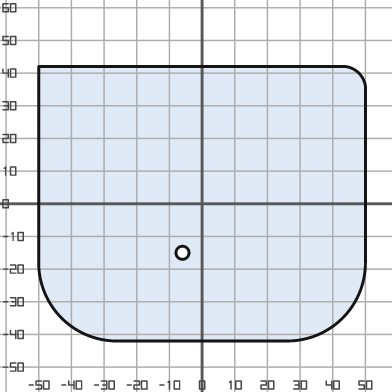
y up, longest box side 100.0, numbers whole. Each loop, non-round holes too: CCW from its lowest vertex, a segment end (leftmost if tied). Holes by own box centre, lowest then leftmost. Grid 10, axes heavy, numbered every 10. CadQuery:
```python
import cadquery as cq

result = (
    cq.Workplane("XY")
    .moveTo(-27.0, -42.0)
    .lineTo(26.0, -42.0)
    .threePointArc((43.0, -35.0), (50.0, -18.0))
    .lineTo(50.0, 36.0)
    .threePointArc((48.0, 40.0), (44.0, 42.0))
    .lineTo(-50.0, 42.0)
    .lineTo(-50.0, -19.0)
    .threePointArc((-43.0, -35.0), (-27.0, -42.0))
    .close()
    .moveTo(-6.0, -15.0)
    .circle(2.0)
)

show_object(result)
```